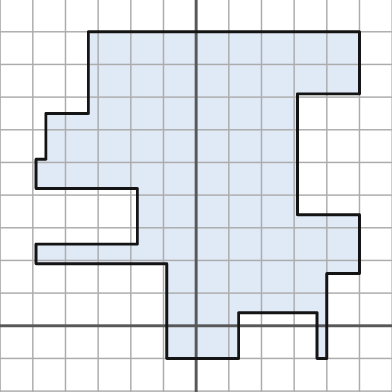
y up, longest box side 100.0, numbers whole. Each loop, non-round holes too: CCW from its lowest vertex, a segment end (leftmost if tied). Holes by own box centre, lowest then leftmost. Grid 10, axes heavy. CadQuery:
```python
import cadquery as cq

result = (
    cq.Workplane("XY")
    .moveTo(-9.0, -10.0)
    .lineTo(13.0, -10.0)
    .lineTo(13.0, 4.0)
    .lineTo(37.0, 4.0)
    .lineTo(37.0, -10.0)
    .lineTo(40.0, -10.0)
    .lineTo(40.0, 16.0)
    .lineTo(50.0, 16.0)
    .lineTo(50.0, 34.0)
    .lineTo(31.0, 34.0)
    .lineTo(31.0, 71.0)
    .lineTo(50.0, 71.0)
    .lineTo(50.0, 90.0)
    .lineTo(-33.0, 90.0)
    .lineTo(-33.0, 65.0)
    .lineTo(-46.0, 65.0)
    .lineTo(-46.0, 51.0)
    .lineTo(-49.0, 51.0)
    .lineTo(-49.0, 42.0)
    .lineTo(-18.0, 42.0)
    .lineTo(-18.0, 25.0)
    .lineTo(-49.0, 25.0)
    .lineTo(-49.0, 19.0)
    .lineTo(-9.0, 19.0)
    .close()
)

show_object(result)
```